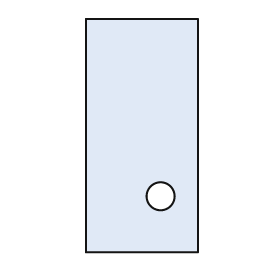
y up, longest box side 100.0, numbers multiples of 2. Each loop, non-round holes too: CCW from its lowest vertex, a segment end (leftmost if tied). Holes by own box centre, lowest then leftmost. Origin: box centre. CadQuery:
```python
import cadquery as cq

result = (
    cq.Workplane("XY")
    .moveTo(-24.0, -50.0)
    .lineTo(24.0, -50.0)
    .lineTo(24.0, 50.0)
    .lineTo(-24.0, 50.0)
    .close()
    .moveTo(8.0, -26.0)
    .circle(6.0)
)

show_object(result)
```